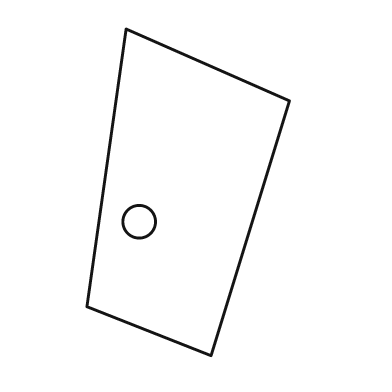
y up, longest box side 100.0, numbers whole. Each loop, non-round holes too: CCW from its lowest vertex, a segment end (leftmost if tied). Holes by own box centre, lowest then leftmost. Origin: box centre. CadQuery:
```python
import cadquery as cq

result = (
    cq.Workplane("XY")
    .moveTo(7.0, -50.0)
    .lineTo(31.0, 28.0)
    .lineTo(-19.0, 50.0)
    .lineTo(-31.0, -35.0)
    .close()
    .moveTo(-15.0, -9.0)
    .circle(5.0)
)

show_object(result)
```